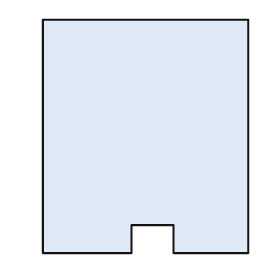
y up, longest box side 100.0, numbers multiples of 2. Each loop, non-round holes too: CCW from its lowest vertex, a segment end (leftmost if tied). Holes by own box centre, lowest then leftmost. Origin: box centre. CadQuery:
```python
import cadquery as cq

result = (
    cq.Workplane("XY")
    .moveTo(-44.0, -50.0)
    .lineTo(-6.0, -50.0)
    .lineTo(-6.0, -38.0)
    .lineTo(12.0, -38.0)
    .lineTo(12.0, -50.0)
    .lineTo(44.0, -50.0)
    .lineTo(44.0, 50.0)
    .lineTo(-44.0, 50.0)
    .close()
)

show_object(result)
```